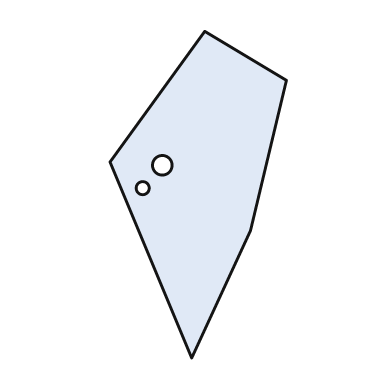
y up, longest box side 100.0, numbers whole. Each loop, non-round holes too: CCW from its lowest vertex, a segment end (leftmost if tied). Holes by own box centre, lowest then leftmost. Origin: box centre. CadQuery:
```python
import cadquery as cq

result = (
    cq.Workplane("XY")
    .moveTo(-2.0, -50.0)
    .lineTo(16.0, -11.0)
    .lineTo(27.0, 35.0)
    .lineTo(2.0, 50.0)
    .lineTo(-27.0, 10.0)
    .close()
    .moveTo(-17.0, 2.0)
    .circle(2.0)
    .moveTo(-11.0, 9.0)
    .circle(3.0)
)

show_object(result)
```